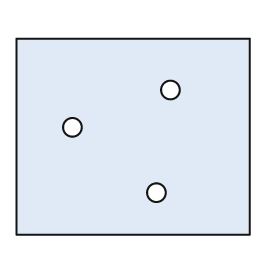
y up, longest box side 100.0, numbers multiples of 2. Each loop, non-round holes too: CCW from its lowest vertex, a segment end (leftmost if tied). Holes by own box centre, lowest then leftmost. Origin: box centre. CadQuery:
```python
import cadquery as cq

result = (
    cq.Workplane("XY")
    .moveTo(-50.0, -42.0)
    .lineTo(50.0, -42.0)
    .lineTo(50.0, 42.0)
    .lineTo(-50.0, 42.0)
    .close()
    .moveTo(10.0, -24.0)
    .circle(4.0)
    .moveTo(-26.0, 4.0)
    .circle(4.0)
    .moveTo(16.0, 20.0)
    .circle(4.0)
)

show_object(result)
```